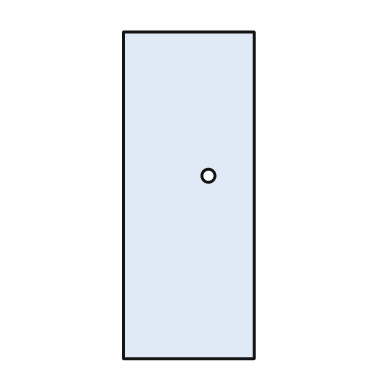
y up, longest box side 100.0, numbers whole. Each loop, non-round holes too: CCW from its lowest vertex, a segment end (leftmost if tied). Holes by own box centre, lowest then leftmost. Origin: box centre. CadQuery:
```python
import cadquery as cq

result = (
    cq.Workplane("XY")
    .moveTo(-20.0, -50.0)
    .lineTo(20.0, -50.0)
    .lineTo(20.0, 50.0)
    .lineTo(-20.0, 50.0)
    .close()
    .moveTo(6.0, 6.0)
    .circle(2.0)
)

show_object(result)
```